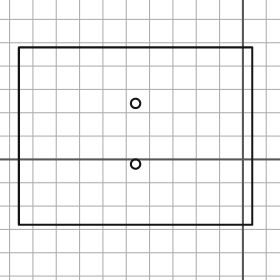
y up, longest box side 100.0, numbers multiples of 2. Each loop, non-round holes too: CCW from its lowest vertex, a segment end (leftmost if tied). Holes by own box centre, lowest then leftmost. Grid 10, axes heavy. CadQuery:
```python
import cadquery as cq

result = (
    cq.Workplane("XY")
    .moveTo(-96.0, -28.0)
    .lineTo(4.0, -28.0)
    .lineTo(4.0, 48.0)
    .lineTo(-96.0, 48.0)
    .close()
    .moveTo(-46.0, -2.0)
    .circle(2.0)
    .moveTo(-46.0, 24.0)
    .circle(2.0)
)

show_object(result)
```